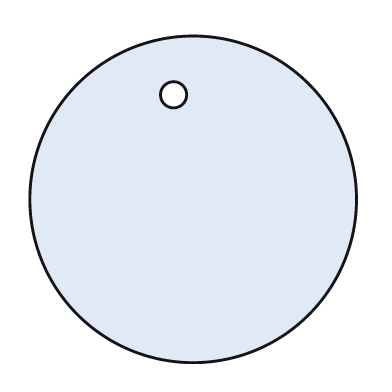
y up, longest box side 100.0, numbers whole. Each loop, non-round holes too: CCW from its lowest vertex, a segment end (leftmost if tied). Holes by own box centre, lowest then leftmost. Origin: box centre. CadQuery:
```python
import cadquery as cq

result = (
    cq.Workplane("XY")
    .moveTo(0.0, 0.0)
    .circle(50.0)
    .moveTo(-6.0, 32.0)
    .circle(4.0)
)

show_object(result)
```